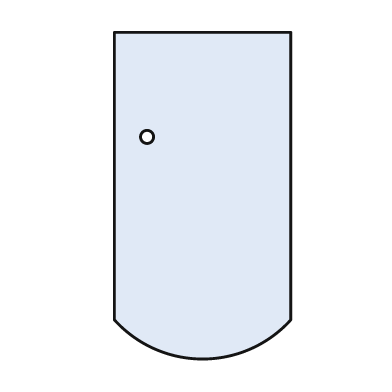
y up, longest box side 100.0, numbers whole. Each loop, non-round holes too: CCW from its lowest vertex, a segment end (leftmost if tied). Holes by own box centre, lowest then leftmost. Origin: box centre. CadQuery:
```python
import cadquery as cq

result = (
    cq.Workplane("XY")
    .moveTo(-27.0, -38.0)
    .threePointArc((0.0, -50.0), (27.0, -38.0))
    .lineTo(27.0, 50.0)
    .lineTo(-27.0, 50.0)
    .close()
    .moveTo(-17.0, 18.0)
    .circle(2.0)
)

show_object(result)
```